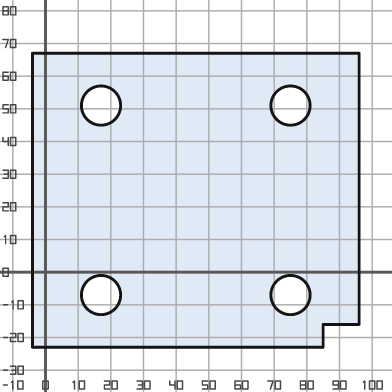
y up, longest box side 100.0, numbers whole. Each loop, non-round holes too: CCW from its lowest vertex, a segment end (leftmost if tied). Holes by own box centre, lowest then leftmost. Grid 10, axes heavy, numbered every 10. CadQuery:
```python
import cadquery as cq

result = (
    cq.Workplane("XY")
    .moveTo(-4.0, -23.0)
    .lineTo(85.0, -23.0)
    .lineTo(85.0, -16.0)
    .lineTo(96.0, -16.0)
    .lineTo(96.0, 67.0)
    .lineTo(-4.0, 67.0)
    .close()
    .moveTo(17.0, -7.0)
    .circle(6.0)
    .moveTo(75.0, -7.0)
    .circle(6.0)
    .moveTo(17.0, 51.0)
    .circle(6.0)
    .moveTo(75.0, 51.0)
    .circle(6.0)
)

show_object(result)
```